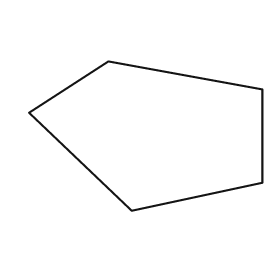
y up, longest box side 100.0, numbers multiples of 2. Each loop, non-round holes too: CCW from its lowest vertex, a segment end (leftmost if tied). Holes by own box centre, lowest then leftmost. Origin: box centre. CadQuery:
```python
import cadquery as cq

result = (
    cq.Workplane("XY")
    .moveTo(-6.0, -32.0)
    .lineTo(50.0, -20.0)
    .lineTo(50.0, 20.0)
    .lineTo(-16.0, 32.0)
    .lineTo(-50.0, 10.0)
    .close()
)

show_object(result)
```